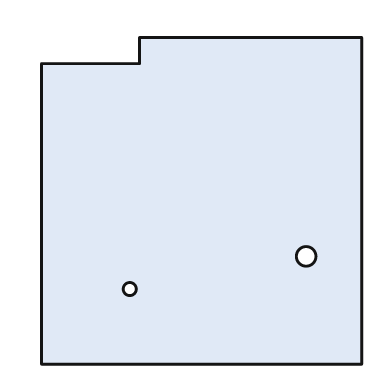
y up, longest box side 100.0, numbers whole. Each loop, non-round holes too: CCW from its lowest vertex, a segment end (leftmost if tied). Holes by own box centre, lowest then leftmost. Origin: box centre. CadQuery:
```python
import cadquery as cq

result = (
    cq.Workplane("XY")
    .moveTo(-49.0, -50.0)
    .lineTo(49.0, -50.0)
    .lineTo(49.0, 50.0)
    .lineTo(-19.0, 50.0)
    .lineTo(-19.0, 42.0)
    .lineTo(-49.0, 42.0)
    .close()
    .moveTo(-22.0, -27.0)
    .circle(2.0)
    .moveTo(32.0, -17.0)
    .circle(3.0)
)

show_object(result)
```